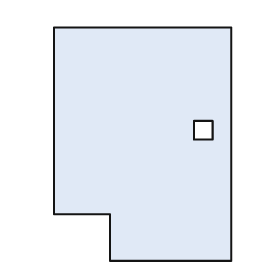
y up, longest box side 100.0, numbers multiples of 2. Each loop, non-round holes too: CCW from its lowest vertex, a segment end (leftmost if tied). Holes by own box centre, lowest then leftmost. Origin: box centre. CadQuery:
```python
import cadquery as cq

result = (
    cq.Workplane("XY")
    .moveTo(-14.0, -50.0)
    .lineTo(38.0, -50.0)
    .lineTo(38.0, 50.0)
    .lineTo(-38.0, 50.0)
    .lineTo(-38.0, -30.0)
    .lineTo(-14.0, -30.0)
    .close()
    .moveTo(22.0, 2.0)
    .lineTo(30.0, 2.0)
    .lineTo(30.0, 10.0)
    .lineTo(22.0, 10.0)
    .close()
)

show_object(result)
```